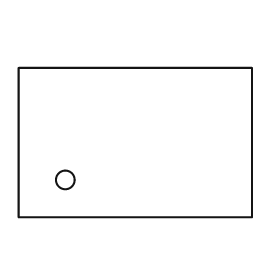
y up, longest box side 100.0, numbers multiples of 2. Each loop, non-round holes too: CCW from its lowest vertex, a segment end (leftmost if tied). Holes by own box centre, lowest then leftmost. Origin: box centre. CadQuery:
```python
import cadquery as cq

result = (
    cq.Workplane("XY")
    .moveTo(-50.0, -32.0)
    .lineTo(50.0, -32.0)
    .lineTo(50.0, 32.0)
    .lineTo(-50.0, 32.0)
    .close()
    .moveTo(-30.0, -16.0)
    .circle(4.0)
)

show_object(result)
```